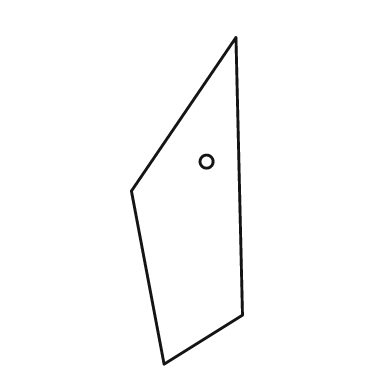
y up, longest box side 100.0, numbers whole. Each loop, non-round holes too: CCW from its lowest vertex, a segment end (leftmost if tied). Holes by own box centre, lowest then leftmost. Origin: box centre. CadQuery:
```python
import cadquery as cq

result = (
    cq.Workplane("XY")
    .moveTo(-7.0, -50.0)
    .lineTo(17.0, -35.0)
    .lineTo(15.0, 50.0)
    .lineTo(-17.0, 3.0)
    .close()
    .moveTo(6.0, 12.0)
    .circle(2.0)
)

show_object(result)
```